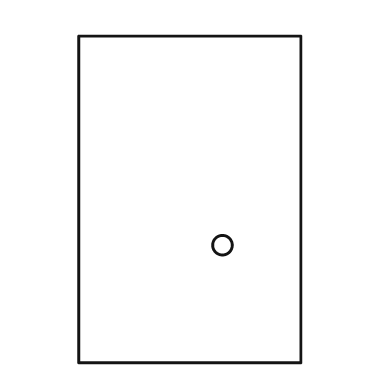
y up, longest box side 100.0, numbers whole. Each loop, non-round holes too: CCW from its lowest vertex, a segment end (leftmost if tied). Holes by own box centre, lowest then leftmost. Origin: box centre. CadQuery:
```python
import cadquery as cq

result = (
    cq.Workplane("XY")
    .moveTo(-34.0, -50.0)
    .lineTo(34.0, -50.0)
    .lineTo(34.0, 50.0)
    .lineTo(-34.0, 50.0)
    .close()
    .moveTo(10.0, -14.0)
    .circle(3.0)
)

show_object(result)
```